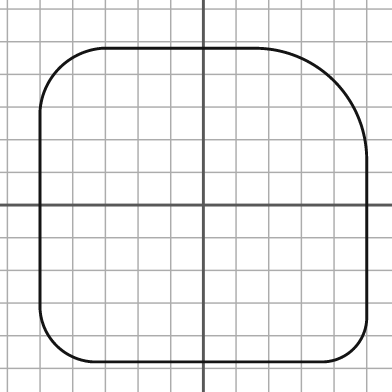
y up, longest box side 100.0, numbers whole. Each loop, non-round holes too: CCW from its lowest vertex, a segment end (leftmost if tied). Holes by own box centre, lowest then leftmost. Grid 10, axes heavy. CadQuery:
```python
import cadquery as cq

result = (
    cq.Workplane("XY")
    .moveTo(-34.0, -48.0)
    .lineTo(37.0, -48.0)
    .threePointArc((46.0, -44.0), (50.0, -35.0))
    .lineTo(50.0, 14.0)
    .threePointArc((40.0, 38.0), (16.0, 48.0))
    .lineTo(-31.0, 48.0)
    .threePointArc((-44.0, 42.0), (-50.0, 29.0))
    .lineTo(-50.0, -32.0)
    .threePointArc((-45.0, -43.0), (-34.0, -48.0))
    .close()
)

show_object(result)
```